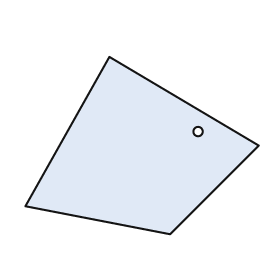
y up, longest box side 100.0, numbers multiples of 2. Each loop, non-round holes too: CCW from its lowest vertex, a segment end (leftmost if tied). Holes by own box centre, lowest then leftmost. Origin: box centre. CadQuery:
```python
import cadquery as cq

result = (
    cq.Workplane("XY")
    .moveTo(12.0, -38.0)
    .lineTo(50.0, 0.0)
    .lineTo(-14.0, 38.0)
    .lineTo(-50.0, -26.0)
    .close()
    .moveTo(24.0, 6.0)
    .circle(2.0)
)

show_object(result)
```